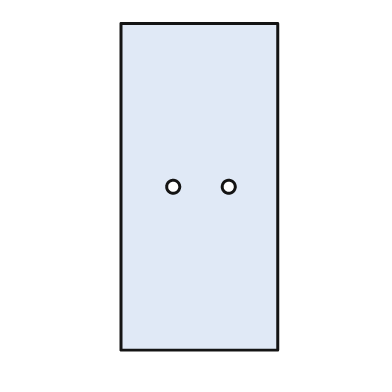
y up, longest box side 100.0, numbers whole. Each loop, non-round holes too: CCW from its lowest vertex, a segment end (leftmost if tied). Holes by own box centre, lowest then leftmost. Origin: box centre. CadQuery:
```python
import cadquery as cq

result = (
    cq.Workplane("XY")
    .moveTo(-24.0, -50.0)
    .lineTo(24.0, -50.0)
    .lineTo(24.0, 50.0)
    .lineTo(-24.0, 50.0)
    .close()
    .moveTo(-8.0, 0.0)
    .circle(2.0)
    .moveTo(9.0, 0.0)
    .circle(2.0)
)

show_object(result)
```